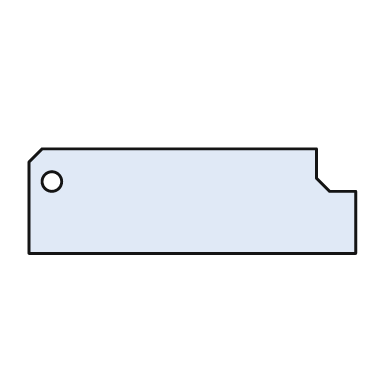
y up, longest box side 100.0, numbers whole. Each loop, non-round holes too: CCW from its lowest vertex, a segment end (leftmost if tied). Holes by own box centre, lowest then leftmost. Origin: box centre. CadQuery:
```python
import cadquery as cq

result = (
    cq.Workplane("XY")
    .moveTo(-50.0, -16.0)
    .lineTo(50.0, -16.0)
    .lineTo(50.0, 3.0)
    .lineTo(42.0, 3.0)
    .lineTo(38.0, 7.0)
    .lineTo(38.0, 16.0)
    .lineTo(-46.0, 16.0)
    .lineTo(-50.0, 12.0)
    .close()
    .moveTo(-43.0, 6.0)
    .circle(3.0)
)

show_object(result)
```